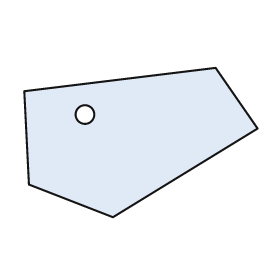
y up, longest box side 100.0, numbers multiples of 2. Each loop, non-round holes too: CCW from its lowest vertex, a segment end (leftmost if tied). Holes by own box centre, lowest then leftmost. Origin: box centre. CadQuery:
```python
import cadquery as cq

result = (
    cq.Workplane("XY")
    .moveTo(-12.0, -32.0)
    .lineTo(50.0, 6.0)
    .lineTo(32.0, 32.0)
    .lineTo(-50.0, 22.0)
    .lineTo(-48.0, -18.0)
    .close()
    .moveTo(-24.0, 12.0)
    .circle(4.0)
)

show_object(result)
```